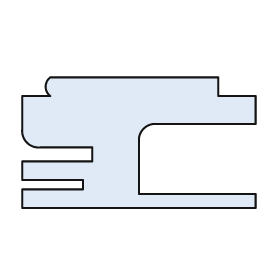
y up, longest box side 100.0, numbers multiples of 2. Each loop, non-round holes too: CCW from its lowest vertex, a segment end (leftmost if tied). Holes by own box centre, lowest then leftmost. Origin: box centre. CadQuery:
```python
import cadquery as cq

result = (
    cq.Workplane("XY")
    .moveTo(-50.0, -28.0)
    .lineTo(50.0, -28.0)
    .lineTo(50.0, -22.0)
    .lineTo(0.0, -22.0)
    .lineTo(0.0, 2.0)
    .threePointArc((2.0, 6.0), (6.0, 8.0))
    .lineTo(50.0, 8.0)
    .lineTo(50.0, 20.0)
    .lineTo(34.0, 20.0)
    .lineTo(34.0, 28.0)
    .lineTo(-38.0, 28.0)
    .threePointArc((-40.0, 24.0), (-38.0, 20.0))
    .lineTo(-50.0, 20.0)
    .lineTo(-50.0, 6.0)
    .threePointArc((-48.0, 0.0), (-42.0, -2.0))
    .lineTo(-20.0, -2.0)
    .lineTo(-20.0, -8.0)
    .lineTo(-50.0, -8.0)
    .lineTo(-50.0, -16.0)
    .lineTo(-24.0, -16.0)
    .lineTo(-24.0, -20.0)
    .lineTo(-50.0, -20.0)
    .close()
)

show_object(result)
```